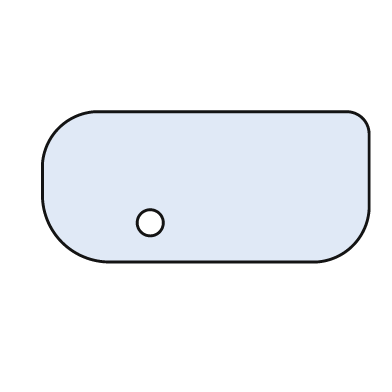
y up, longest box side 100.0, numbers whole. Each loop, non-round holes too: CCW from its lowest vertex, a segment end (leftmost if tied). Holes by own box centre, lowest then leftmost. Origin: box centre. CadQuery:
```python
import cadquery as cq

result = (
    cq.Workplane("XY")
    .moveTo(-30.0, -23.0)
    .lineTo(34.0, -23.0)
    .threePointArc((45.0, -18.0), (50.0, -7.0))
    .lineTo(50.0, 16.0)
    .threePointArc((48.0, 21.0), (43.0, 23.0))
    .lineTo(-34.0, 23.0)
    .threePointArc((-45.0, 18.0), (-50.0, 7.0))
    .lineTo(-50.0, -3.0)
    .threePointArc((-44.0, -17.0), (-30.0, -23.0))
    .close()
    .moveTo(-17.0, -11.0)
    .circle(4.0)
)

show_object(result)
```